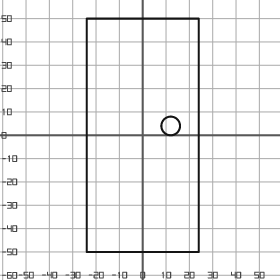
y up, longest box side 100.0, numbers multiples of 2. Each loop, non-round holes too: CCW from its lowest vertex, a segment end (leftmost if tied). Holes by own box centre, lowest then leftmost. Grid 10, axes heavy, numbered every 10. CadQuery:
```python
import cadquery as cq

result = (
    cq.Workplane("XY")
    .moveTo(-24.0, -50.0)
    .lineTo(24.0, -50.0)
    .lineTo(24.0, 50.0)
    .lineTo(-24.0, 50.0)
    .close()
    .moveTo(12.0, 4.0)
    .circle(4.0)
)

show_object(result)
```